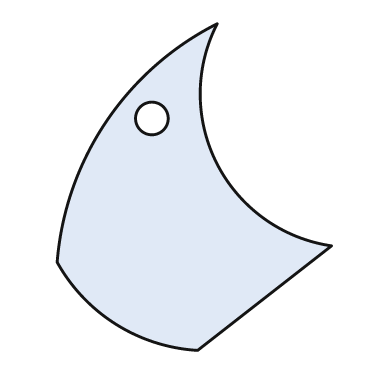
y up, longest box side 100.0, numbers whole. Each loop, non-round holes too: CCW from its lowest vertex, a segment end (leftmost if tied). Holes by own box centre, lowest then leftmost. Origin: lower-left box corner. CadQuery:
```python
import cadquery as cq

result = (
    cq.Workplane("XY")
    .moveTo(43.0, 0.0)
    .lineTo(84.0, 32.0)
    .threePointArc((49.0, 57.0), (49.0, 100.0))
    .threePointArc((15.0, 70.0), (0.0, 27.0))
    .threePointArc((18.0, 8.0), (43.0, 0.0))
    .close()
    .moveTo(29.0, 71.0)
    .circle(5.0)
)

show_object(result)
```